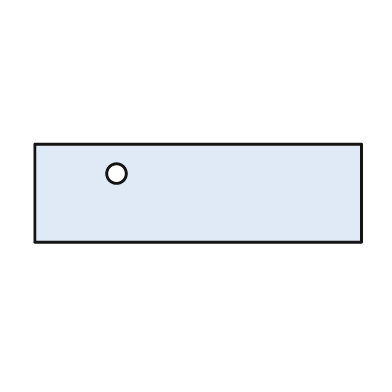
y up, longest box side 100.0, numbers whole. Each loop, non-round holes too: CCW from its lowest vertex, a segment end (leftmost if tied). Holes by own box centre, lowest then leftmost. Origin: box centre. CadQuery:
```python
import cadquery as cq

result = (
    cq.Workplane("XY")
    .moveTo(-50.0, -15.0)
    .lineTo(50.0, -15.0)
    .lineTo(50.0, 15.0)
    .lineTo(-50.0, 15.0)
    .close()
    .moveTo(-25.0, 6.0)
    .circle(3.0)
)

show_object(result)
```